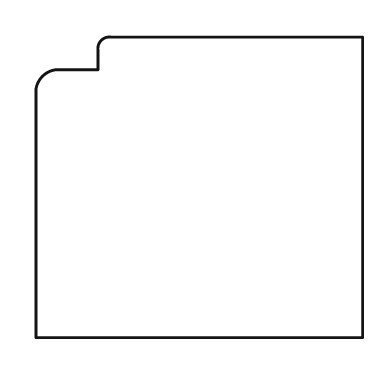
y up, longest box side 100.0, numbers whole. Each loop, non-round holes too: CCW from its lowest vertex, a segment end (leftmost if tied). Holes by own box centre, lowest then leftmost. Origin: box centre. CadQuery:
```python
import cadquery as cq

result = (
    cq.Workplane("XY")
    .moveTo(-50.0, -46.0)
    .lineTo(50.0, -46.0)
    .lineTo(50.0, 46.0)
    .lineTo(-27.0, 46.0)
    .threePointArc((-30.0, 45.0), (-31.0, 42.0))
    .lineTo(-31.0, 36.0)
    .lineTo(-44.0, 36.0)
    .threePointArc((-48.0, 34.0), (-50.0, 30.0))
    .close()
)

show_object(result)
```